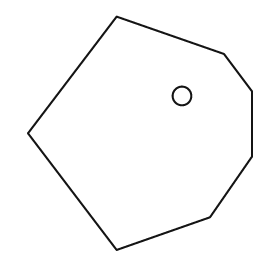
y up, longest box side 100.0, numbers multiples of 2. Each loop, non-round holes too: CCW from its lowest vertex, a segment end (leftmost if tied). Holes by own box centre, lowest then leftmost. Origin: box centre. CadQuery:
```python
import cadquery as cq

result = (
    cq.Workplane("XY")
    .moveTo(-10.0, -50.0)
    .lineTo(30.0, -36.0)
    .lineTo(48.0, -10.0)
    .lineTo(48.0, 18.0)
    .lineTo(36.0, 34.0)
    .lineTo(-10.0, 50.0)
    .lineTo(-48.0, 0.0)
    .close()
    .moveTo(18.0, 16.0)
    .circle(4.0)
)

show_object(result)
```